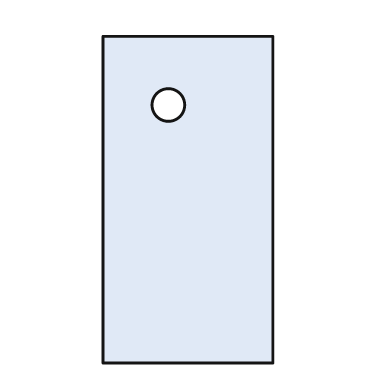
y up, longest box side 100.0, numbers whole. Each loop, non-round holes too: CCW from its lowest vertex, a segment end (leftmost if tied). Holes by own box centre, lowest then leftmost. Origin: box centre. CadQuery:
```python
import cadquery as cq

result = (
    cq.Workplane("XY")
    .moveTo(-26.0, -50.0)
    .lineTo(26.0, -50.0)
    .lineTo(26.0, 50.0)
    .lineTo(-26.0, 50.0)
    .close()
    .moveTo(-6.0, 29.0)
    .circle(5.0)
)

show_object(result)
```